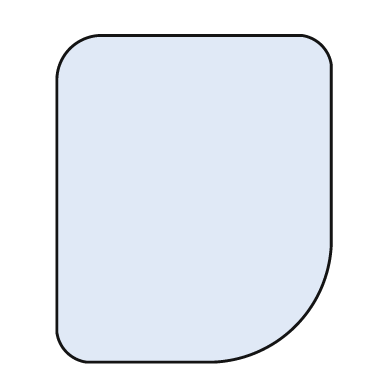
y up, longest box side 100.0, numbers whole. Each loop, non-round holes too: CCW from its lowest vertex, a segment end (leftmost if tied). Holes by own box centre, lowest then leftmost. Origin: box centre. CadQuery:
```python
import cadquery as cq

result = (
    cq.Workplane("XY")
    .moveTo(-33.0, -50.0)
    .lineTo(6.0, -50.0)
    .threePointArc((31.0, -39.0), (42.0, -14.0))
    .lineTo(42.0, 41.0)
    .threePointArc((39.0, 47.0), (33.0, 50.0))
    .lineTo(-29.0, 50.0)
    .threePointArc((-38.0, 46.0), (-42.0, 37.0))
    .lineTo(-42.0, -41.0)
    .threePointArc((-39.0, -47.0), (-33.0, -50.0))
    .close()
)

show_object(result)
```